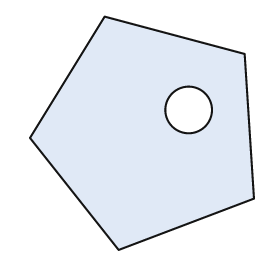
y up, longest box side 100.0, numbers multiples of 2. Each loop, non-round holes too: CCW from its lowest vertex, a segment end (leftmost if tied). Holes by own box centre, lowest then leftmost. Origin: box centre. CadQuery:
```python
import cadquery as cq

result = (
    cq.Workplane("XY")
    .moveTo(-10.0, -50.0)
    .lineTo(48.0, -28.0)
    .lineTo(44.0, 34.0)
    .lineTo(-16.0, 50.0)
    .lineTo(-48.0, -2.0)
    .close()
    .moveTo(20.0, 10.0)
    .circle(10.0)
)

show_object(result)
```